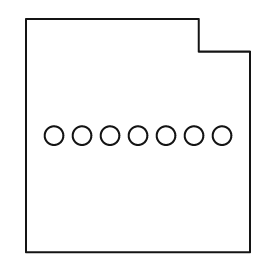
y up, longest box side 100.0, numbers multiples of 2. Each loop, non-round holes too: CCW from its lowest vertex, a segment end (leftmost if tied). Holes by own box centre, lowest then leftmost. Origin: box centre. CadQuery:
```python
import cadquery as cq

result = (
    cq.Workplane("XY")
    .moveTo(-48.0, -50.0)
    .lineTo(48.0, -50.0)
    .lineTo(48.0, 36.0)
    .lineTo(26.0, 36.0)
    .lineTo(26.0, 50.0)
    .lineTo(-48.0, 50.0)
    .close()
    .moveTo(-36.0, 0.0)
    .circle(4.0)
    .moveTo(-24.0, 0.0)
    .circle(4.0)
    .moveTo(-12.0, 0.0)
    .circle(4.0)
    .moveTo(0.0, 0.0)
    .circle(4.0)
    .moveTo(12.0, 0.0)
    .circle(4.0)
    .moveTo(24.0, 0.0)
    .circle(4.0)
    .moveTo(36.0, 0.0)
    .circle(4.0)
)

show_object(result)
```